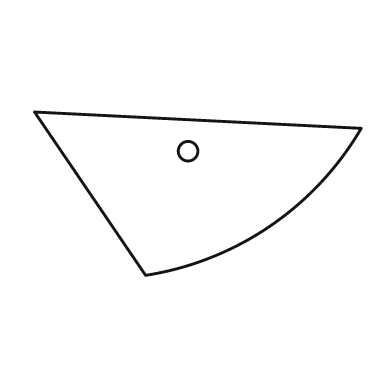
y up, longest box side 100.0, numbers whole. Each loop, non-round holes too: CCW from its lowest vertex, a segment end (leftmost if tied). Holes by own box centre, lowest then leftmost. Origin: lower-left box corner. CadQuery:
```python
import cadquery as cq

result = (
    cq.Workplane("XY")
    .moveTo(34.0, 0.0)
    .threePointArc((72.0, 15.0), (100.0, 45.0))
    .lineTo(0.0, 50.0)
    .close()
    .moveTo(47.0, 38.0)
    .circle(3.0)
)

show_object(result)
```